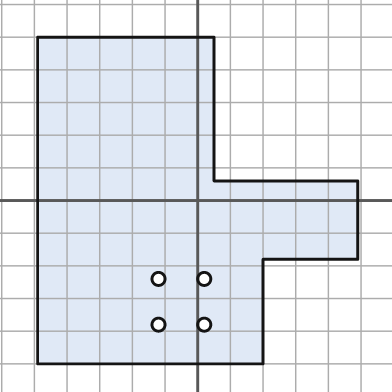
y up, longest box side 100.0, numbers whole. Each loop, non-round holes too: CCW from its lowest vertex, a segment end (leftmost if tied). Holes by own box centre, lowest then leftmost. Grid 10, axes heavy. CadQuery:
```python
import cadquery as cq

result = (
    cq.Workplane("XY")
    .moveTo(-49.0, -50.0)
    .lineTo(20.0, -50.0)
    .lineTo(20.0, -18.0)
    .lineTo(49.0, -18.0)
    .lineTo(49.0, 6.0)
    .lineTo(5.0, 6.0)
    .lineTo(5.0, 50.0)
    .lineTo(-49.0, 50.0)
    .close()
    .moveTo(-12.0, -38.0)
    .circle(2.0)
    .moveTo(2.0, -38.0)
    .circle(2.0)
    .moveTo(-12.0, -24.0)
    .circle(2.0)
    .moveTo(2.0, -24.0)
    .circle(2.0)
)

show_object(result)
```